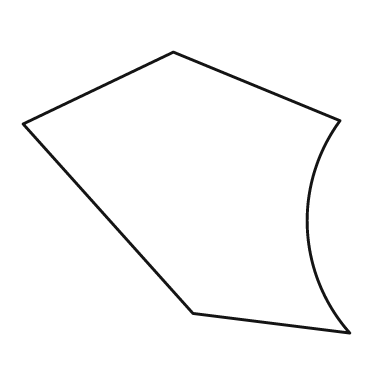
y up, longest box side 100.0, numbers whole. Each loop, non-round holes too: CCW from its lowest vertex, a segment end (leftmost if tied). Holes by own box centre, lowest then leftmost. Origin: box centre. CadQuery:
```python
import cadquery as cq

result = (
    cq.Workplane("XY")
    .moveTo(50.0, -43.0)
    .threePointArc((37.0, -11.0), (47.0, 22.0))
    .lineTo(-4.0, 43.0)
    .lineTo(-50.0, 21.0)
    .lineTo(2.0, -37.0)
    .close()
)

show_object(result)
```